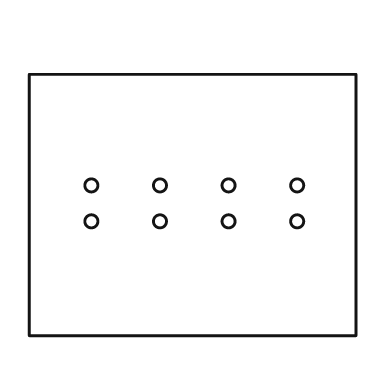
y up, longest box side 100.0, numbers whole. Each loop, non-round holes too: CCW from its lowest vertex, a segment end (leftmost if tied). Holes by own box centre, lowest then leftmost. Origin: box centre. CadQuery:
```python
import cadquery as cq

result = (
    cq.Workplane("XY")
    .moveTo(-50.0, -40.0)
    .lineTo(50.0, -40.0)
    .lineTo(50.0, 40.0)
    .lineTo(-50.0, 40.0)
    .close()
    .moveTo(-31.0, -5.0)
    .circle(2.0)
    .moveTo(-10.0, -5.0)
    .circle(2.0)
    .moveTo(11.0, -5.0)
    .circle(2.0)
    .moveTo(32.0, -5.0)
    .circle(2.0)
    .moveTo(-31.0, 6.0)
    .circle(2.0)
    .moveTo(-10.0, 6.0)
    .circle(2.0)
    .moveTo(11.0, 6.0)
    .circle(2.0)
    .moveTo(32.0, 6.0)
    .circle(2.0)
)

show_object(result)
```